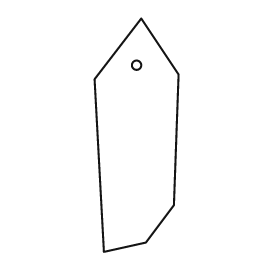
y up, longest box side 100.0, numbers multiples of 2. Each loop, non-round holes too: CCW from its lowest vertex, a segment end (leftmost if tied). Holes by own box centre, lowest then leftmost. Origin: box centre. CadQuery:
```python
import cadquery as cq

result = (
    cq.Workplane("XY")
    .moveTo(-14.0, -50.0)
    .lineTo(4.0, -46.0)
    .lineTo(16.0, -30.0)
    .lineTo(18.0, 26.0)
    .lineTo(2.0, 50.0)
    .lineTo(-18.0, 24.0)
    .close()
    .moveTo(0.0, 30.0)
    .circle(2.0)
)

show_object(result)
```